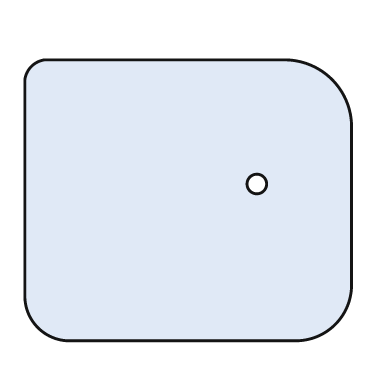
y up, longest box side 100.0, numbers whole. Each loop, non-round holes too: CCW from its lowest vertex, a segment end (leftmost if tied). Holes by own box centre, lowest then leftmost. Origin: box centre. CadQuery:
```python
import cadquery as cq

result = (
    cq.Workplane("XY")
    .moveTo(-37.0, -43.0)
    .lineTo(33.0, -43.0)
    .threePointArc((45.0, -38.0), (50.0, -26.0))
    .lineTo(50.0, 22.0)
    .threePointArc((44.0, 37.0), (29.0, 43.0))
    .lineTo(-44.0, 43.0)
    .threePointArc((-48.0, 41.0), (-50.0, 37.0))
    .lineTo(-50.0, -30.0)
    .threePointArc((-46.0, -39.0), (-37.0, -43.0))
    .close()
    .moveTo(21.0, 5.0)
    .circle(3.0)
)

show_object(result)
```